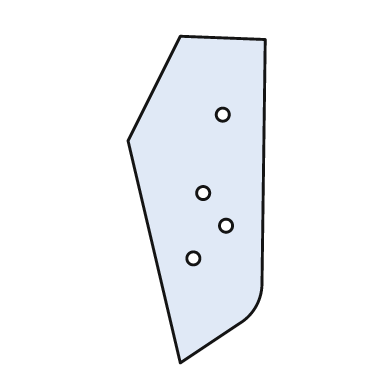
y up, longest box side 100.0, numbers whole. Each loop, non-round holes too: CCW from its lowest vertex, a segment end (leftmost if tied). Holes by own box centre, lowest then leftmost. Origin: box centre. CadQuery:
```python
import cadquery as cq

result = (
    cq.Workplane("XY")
    .moveTo(-5.0, -50.0)
    .lineTo(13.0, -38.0)
    .threePointArc((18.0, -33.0), (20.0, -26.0))
    .lineTo(21.0, 49.0)
    .lineTo(-5.0, 50.0)
    .lineTo(-21.0, 18.0)
    .close()
    .moveTo(-1.0, -18.0)
    .circle(2.0)
    .moveTo(9.0, -8.0)
    .circle(2.0)
    .moveTo(2.0, 2.0)
    .circle(2.0)
    .moveTo(8.0, 26.0)
    .circle(2.0)
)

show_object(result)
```